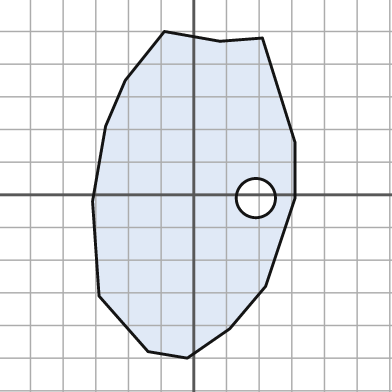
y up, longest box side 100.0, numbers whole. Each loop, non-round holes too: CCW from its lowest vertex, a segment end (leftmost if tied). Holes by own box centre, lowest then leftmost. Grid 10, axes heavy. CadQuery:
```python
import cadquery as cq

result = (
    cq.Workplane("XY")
    .moveTo(-2.0, -50.0)
    .lineTo(11.0, -41.0)
    .lineTo(22.0, -28.0)
    .lineTo(31.0, -1.0)
    .lineTo(31.0, 16.0)
    .lineTo(21.0, 48.0)
    .lineTo(8.0, 47.0)
    .lineTo(-9.0, 50.0)
    .lineTo(-21.0, 35.0)
    .lineTo(-27.0, 21.0)
    .lineTo(-31.0, -2.0)
    .lineTo(-29.0, -31.0)
    .lineTo(-14.0, -48.0)
    .close()
    .moveTo(19.0, -1.0)
    .circle(6.0)
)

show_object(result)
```